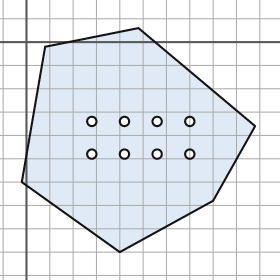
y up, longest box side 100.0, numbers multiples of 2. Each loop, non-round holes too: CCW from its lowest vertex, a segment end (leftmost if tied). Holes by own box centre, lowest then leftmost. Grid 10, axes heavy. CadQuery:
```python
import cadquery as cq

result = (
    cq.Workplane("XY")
    .moveTo(40.0, -90.0)
    .lineTo(80.0, -68.0)
    .lineTo(98.0, -36.0)
    .lineTo(48.0, 6.0)
    .lineTo(8.0, -2.0)
    .lineTo(-2.0, -60.0)
    .close()
    .moveTo(28.0, -48.0)
    .circle(2.0)
    .moveTo(42.0, -48.0)
    .circle(2.0)
    .moveTo(56.0, -48.0)
    .circle(2.0)
    .moveTo(70.0, -48.0)
    .circle(2.0)
    .moveTo(28.0, -34.0)
    .circle(2.0)
    .moveTo(42.0, -34.0)
    .circle(2.0)
    .moveTo(56.0, -34.0)
    .circle(2.0)
    .moveTo(70.0, -34.0)
    .circle(2.0)
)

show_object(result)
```